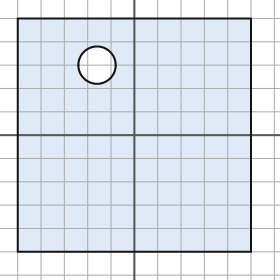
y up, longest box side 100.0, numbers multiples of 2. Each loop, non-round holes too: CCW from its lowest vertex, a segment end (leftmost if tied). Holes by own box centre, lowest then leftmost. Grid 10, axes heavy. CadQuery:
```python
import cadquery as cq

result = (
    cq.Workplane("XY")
    .moveTo(-50.0, -50.0)
    .lineTo(50.0, -50.0)
    .lineTo(50.0, 50.0)
    .lineTo(-50.0, 50.0)
    .close()
    .moveTo(-16.0, 30.0)
    .circle(8.0)
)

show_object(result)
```